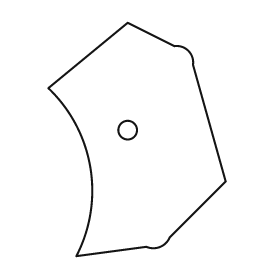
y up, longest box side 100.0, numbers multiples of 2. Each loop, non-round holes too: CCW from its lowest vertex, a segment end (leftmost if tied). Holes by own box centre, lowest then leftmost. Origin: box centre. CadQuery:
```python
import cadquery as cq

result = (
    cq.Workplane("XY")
    .moveTo(-26.0, -50.0)
    .lineTo(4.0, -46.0)
    .threePointArc((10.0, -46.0), (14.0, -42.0))
    .lineTo(38.0, -18.0)
    .lineTo(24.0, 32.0)
    .threePointArc((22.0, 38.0), (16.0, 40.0))
    .lineTo(-4.0, 50.0)
    .lineTo(-38.0, 22.0)
    .threePointArc((-20.0, -12.0), (-26.0, -50.0))
    .close()
    .moveTo(-4.0, 4.0)
    .circle(4.0)
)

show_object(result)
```